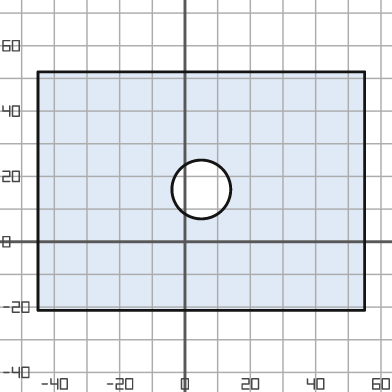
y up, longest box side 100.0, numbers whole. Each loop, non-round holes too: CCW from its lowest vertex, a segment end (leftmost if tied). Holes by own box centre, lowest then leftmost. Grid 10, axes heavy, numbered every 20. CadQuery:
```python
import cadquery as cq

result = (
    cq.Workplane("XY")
    .moveTo(-45.0, -21.0)
    .lineTo(55.0, -21.0)
    .lineTo(55.0, 52.0)
    .lineTo(-45.0, 52.0)
    .close()
    .moveTo(5.0, 16.0)
    .circle(9.0)
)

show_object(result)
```